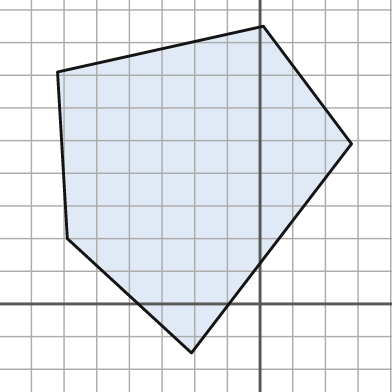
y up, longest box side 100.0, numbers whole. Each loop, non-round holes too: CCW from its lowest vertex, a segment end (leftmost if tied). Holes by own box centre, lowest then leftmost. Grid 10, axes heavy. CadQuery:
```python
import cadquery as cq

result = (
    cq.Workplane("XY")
    .moveTo(-21.0, -15.0)
    .lineTo(28.0, 49.0)
    .lineTo(1.0, 85.0)
    .lineTo(-62.0, 71.0)
    .lineTo(-59.0, 20.0)
    .close()
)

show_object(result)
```